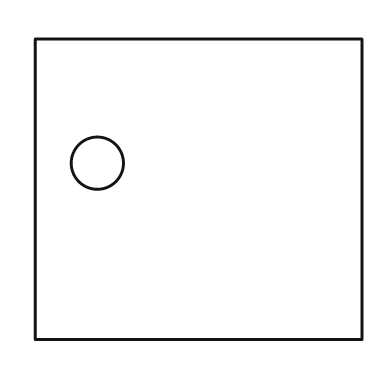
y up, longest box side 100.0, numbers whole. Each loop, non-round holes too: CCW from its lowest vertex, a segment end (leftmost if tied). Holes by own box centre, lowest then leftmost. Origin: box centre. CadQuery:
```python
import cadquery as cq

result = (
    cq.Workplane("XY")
    .moveTo(-50.0, -46.0)
    .lineTo(50.0, -46.0)
    .lineTo(50.0, 46.0)
    .lineTo(-50.0, 46.0)
    .close()
    .moveTo(-31.0, 8.0)
    .circle(8.0)
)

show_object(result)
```